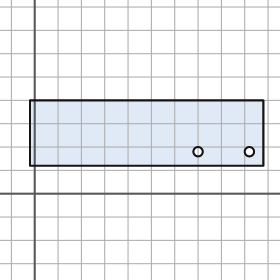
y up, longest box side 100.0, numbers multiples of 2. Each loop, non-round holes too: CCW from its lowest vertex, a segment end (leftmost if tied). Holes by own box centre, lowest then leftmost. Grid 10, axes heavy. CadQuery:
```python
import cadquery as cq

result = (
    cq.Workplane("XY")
    .moveTo(-2.0, 12.0)
    .lineTo(98.0, 12.0)
    .lineTo(98.0, 40.0)
    .lineTo(-2.0, 40.0)
    .close()
    .moveTo(70.0, 18.0)
    .circle(2.0)
    .moveTo(92.0, 18.0)
    .circle(2.0)
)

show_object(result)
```